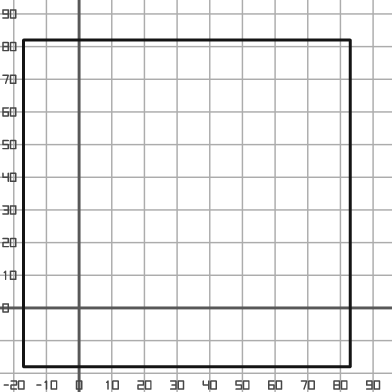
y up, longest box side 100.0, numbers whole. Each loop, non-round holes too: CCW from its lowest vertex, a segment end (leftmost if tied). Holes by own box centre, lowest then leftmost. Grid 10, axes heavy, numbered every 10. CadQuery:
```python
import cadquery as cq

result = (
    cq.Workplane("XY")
    .moveTo(-17.0, -18.0)
    .lineTo(83.0, -18.0)
    .lineTo(83.0, 82.0)
    .lineTo(-17.0, 82.0)
    .close()
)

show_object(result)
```